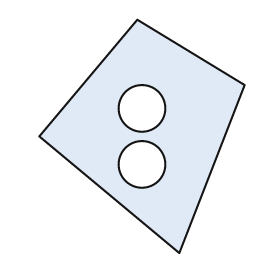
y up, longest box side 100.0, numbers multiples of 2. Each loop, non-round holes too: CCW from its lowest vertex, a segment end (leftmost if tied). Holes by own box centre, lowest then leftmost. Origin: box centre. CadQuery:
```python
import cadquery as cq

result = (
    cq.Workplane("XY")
    .moveTo(16.0, -50.0)
    .lineTo(44.0, 22.0)
    .lineTo(-2.0, 50.0)
    .lineTo(-44.0, 0.0)
    .close()
    .moveTo(0.0, -12.0)
    .circle(10.0)
    .moveTo(0.0, 12.0)
    .circle(10.0)
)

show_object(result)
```